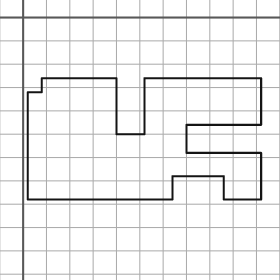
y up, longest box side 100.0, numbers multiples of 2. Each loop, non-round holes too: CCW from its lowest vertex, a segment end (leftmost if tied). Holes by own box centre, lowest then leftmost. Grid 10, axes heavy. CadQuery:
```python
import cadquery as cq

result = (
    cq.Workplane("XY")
    .moveTo(2.0, -78.0)
    .lineTo(64.0, -78.0)
    .lineTo(64.0, -68.0)
    .lineTo(86.0, -68.0)
    .lineTo(86.0, -78.0)
    .lineTo(102.0, -78.0)
    .lineTo(102.0, -58.0)
    .lineTo(70.0, -58.0)
    .lineTo(70.0, -46.0)
    .lineTo(102.0, -46.0)
    .lineTo(102.0, -26.0)
    .lineTo(52.0, -26.0)
    .lineTo(52.0, -50.0)
    .lineTo(40.0, -50.0)
    .lineTo(40.0, -26.0)
    .lineTo(8.0, -26.0)
    .lineTo(8.0, -32.0)
    .lineTo(2.0, -32.0)
    .close()
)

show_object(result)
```